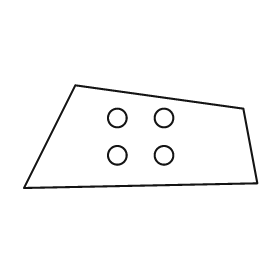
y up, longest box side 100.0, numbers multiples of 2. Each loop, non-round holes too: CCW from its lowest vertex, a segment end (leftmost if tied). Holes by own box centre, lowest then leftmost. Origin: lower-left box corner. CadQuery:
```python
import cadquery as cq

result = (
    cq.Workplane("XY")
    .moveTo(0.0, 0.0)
    .lineTo(100.0, 2.0)
    .lineTo(94.0, 34.0)
    .lineTo(22.0, 44.0)
    .close()
    .moveTo(40.0, 14.0)
    .circle(4.0)
    .moveTo(60.0, 14.0)
    .circle(4.0)
    .moveTo(40.0, 30.0)
    .circle(4.0)
    .moveTo(60.0, 30.0)
    .circle(4.0)
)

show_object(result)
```